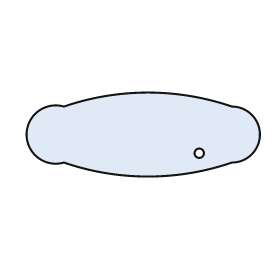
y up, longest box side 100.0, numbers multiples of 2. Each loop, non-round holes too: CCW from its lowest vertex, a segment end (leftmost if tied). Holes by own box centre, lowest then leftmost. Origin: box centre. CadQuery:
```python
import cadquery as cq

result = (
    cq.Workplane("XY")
    .moveTo(-34.0, -12.0)
    .threePointArc((2.0, -18.0), (38.0, -12.0))
    .threePointArc((50.0, 0.0), (38.0, 12.0))
    .threePointArc((2.0, 18.0), (-34.0, 12.0))
    .threePointArc((-50.0, 0.0), (-34.0, -12.0))
    .close()
    .moveTo(24.0, -8.0)
    .circle(2.0)
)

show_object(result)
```